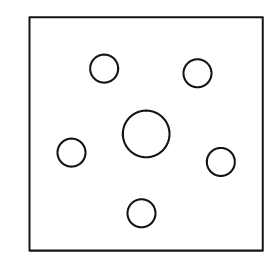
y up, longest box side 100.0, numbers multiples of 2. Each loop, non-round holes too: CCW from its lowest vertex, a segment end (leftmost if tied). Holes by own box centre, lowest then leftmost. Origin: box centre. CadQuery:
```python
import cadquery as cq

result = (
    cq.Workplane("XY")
    .moveTo(-50.0, -50.0)
    .lineTo(50.0, -50.0)
    .lineTo(50.0, 50.0)
    .lineTo(-50.0, 50.0)
    .close()
    .moveTo(-2.0, -34.0)
    .circle(6.0)
    .moveTo(32.0, -12.0)
    .circle(6.0)
    .moveTo(-32.0, -8.0)
    .circle(6.0)
    .moveTo(0.0, 0.0)
    .circle(10.0)
    .moveTo(22.0, 26.0)
    .circle(6.0)
    .moveTo(-18.0, 28.0)
    .circle(6.0)
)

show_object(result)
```